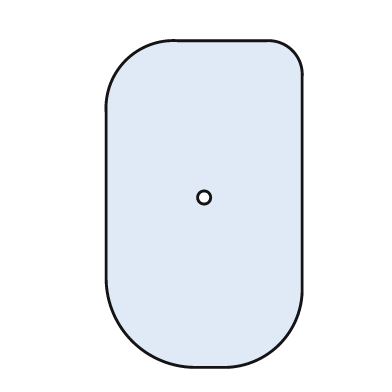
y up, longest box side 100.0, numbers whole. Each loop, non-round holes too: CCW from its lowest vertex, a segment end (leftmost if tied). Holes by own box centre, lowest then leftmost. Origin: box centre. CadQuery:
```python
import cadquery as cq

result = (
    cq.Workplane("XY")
    .moveTo(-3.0, -50.0)
    .lineTo(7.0, -50.0)
    .threePointArc((23.0, -43.0), (30.0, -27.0))
    .lineTo(30.0, 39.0)
    .threePointArc((27.0, 47.0), (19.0, 50.0))
    .lineTo(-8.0, 50.0)
    .threePointArc((-24.0, 44.0), (-30.0, 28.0))
    .lineTo(-30.0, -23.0)
    .threePointArc((-22.0, -42.0), (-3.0, -50.0))
    .close()
    .moveTo(0.0, 2.0)
    .circle(2.0)
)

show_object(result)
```